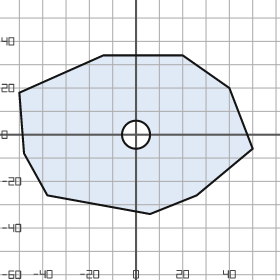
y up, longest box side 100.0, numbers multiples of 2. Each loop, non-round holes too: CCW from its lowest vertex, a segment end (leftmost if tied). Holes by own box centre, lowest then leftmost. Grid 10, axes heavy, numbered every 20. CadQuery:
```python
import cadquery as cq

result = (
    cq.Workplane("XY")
    .moveTo(6.0, -34.0)
    .lineTo(26.0, -26.0)
    .lineTo(50.0, -6.0)
    .lineTo(40.0, 20.0)
    .lineTo(20.0, 34.0)
    .lineTo(-14.0, 34.0)
    .lineTo(-50.0, 18.0)
    .lineTo(-48.0, -8.0)
    .lineTo(-38.0, -26.0)
    .close()
    .moveTo(0.0, 0.0)
    .circle(6.0)
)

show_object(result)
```